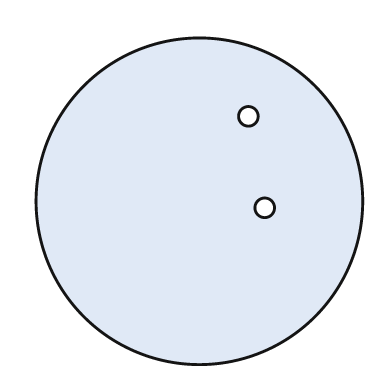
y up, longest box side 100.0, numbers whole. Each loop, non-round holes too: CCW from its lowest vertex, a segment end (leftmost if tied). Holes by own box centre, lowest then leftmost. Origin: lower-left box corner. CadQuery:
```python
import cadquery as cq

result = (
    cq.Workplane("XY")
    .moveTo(50.0, 50.0)
    .circle(50.0)
    .moveTo(70.0, 48.0)
    .circle(3.0)
    .moveTo(65.0, 76.0)
    .circle(3.0)
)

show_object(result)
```